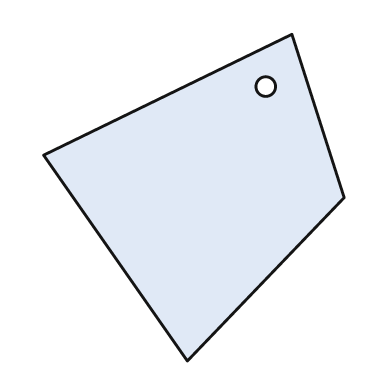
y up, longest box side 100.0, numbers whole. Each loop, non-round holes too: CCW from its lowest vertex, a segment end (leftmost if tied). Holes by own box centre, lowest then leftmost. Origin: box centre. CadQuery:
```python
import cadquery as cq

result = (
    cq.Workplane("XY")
    .moveTo(-2.0, -50.0)
    .lineTo(46.0, 0.0)
    .lineTo(30.0, 50.0)
    .lineTo(-46.0, 13.0)
    .close()
    .moveTo(22.0, 34.0)
    .circle(3.0)
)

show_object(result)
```